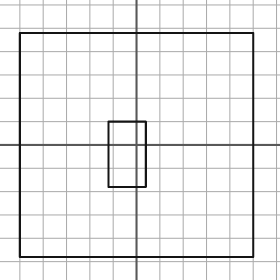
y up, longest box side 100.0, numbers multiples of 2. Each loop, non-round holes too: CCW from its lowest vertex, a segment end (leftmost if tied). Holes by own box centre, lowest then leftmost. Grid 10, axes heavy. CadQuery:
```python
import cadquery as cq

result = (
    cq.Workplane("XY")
    .moveTo(-50.0, -48.0)
    .lineTo(50.0, -48.0)
    .lineTo(50.0, 48.0)
    .lineTo(-50.0, 48.0)
    .close()
    .moveTo(-12.0, -18.0)
    .lineTo(4.0, -18.0)
    .lineTo(4.0, 10.0)
    .lineTo(-12.0, 10.0)
    .close()
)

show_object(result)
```